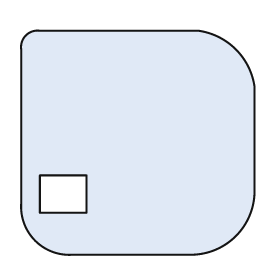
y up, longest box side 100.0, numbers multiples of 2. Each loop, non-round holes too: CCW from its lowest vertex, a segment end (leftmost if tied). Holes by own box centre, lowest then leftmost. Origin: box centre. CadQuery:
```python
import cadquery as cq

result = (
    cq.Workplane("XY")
    .moveTo(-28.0, -48.0)
    .lineTo(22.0, -48.0)
    .threePointArc((42.0, -40.0), (50.0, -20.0))
    .lineTo(50.0, 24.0)
    .threePointArc((42.0, 40.0), (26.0, 48.0))
    .lineTo(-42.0, 48.0)
    .threePointArc((-48.0, 46.0), (-50.0, 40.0))
    .lineTo(-50.0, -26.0)
    .threePointArc((-44.0, -42.0), (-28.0, -48.0))
    .close()
    .moveTo(-42.0, -30.0)
    .lineTo(-22.0, -30.0)
    .lineTo(-22.0, -14.0)
    .lineTo(-42.0, -14.0)
    .close()
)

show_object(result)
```